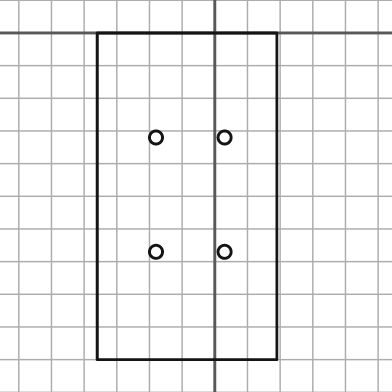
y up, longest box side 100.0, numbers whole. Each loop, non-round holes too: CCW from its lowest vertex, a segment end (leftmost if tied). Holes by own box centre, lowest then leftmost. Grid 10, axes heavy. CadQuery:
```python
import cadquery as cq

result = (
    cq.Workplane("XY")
    .moveTo(-36.0, -100.0)
    .lineTo(19.0, -100.0)
    .lineTo(19.0, 0.0)
    .lineTo(-36.0, 0.0)
    .close()
    .moveTo(-18.0, -67.0)
    .circle(2.0)
    .moveTo(3.0, -67.0)
    .circle(2.0)
    .moveTo(-18.0, -32.0)
    .circle(2.0)
    .moveTo(3.0, -32.0)
    .circle(2.0)
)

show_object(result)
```